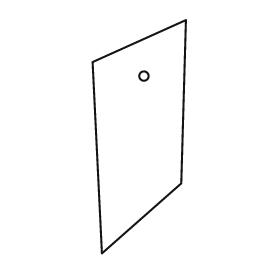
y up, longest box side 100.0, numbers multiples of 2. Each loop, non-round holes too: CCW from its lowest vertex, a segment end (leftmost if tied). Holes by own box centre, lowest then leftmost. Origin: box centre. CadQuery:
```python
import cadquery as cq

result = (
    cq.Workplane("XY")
    .moveTo(-16.0, -50.0)
    .lineTo(18.0, -20.0)
    .lineTo(20.0, 50.0)
    .lineTo(-20.0, 32.0)
    .close()
    .moveTo(2.0, 26.0)
    .circle(2.0)
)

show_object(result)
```